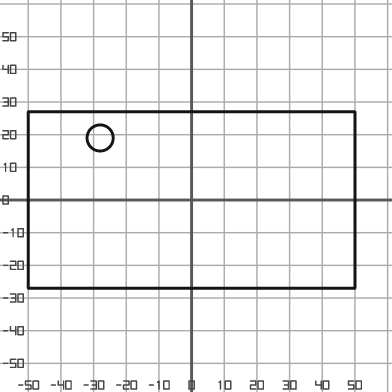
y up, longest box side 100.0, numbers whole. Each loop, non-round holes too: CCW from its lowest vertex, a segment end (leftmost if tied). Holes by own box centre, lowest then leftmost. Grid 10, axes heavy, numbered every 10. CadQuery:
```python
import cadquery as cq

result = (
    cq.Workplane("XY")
    .moveTo(-50.0, -27.0)
    .lineTo(50.0, -27.0)
    .lineTo(50.0, 27.0)
    .lineTo(-50.0, 27.0)
    .close()
    .moveTo(-28.0, 19.0)
    .circle(4.0)
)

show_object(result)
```